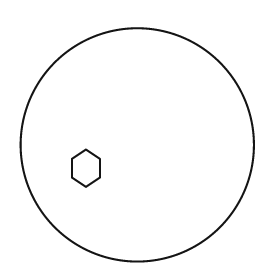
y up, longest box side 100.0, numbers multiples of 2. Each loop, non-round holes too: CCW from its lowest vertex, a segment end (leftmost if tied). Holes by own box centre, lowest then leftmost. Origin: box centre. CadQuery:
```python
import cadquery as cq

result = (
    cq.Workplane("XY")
    .moveTo(0.0, 0.0)
    .circle(50.0)
    .moveTo(-22.0, -18.0)
    .lineTo(-16.0, -14.0)
    .lineTo(-16.0, -6.0)
    .lineTo(-22.0, -2.0)
    .lineTo(-28.0, -6.0)
    .lineTo(-28.0, -14.0)
    .close()
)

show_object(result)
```